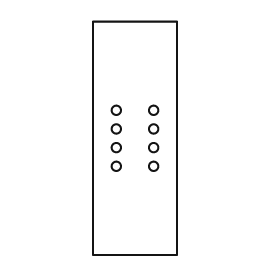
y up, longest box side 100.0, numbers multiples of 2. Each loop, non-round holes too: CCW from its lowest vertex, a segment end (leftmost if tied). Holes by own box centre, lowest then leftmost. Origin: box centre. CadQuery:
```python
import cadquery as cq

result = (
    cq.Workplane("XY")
    .moveTo(-18.0, -50.0)
    .lineTo(18.0, -50.0)
    .lineTo(18.0, 50.0)
    .lineTo(-18.0, 50.0)
    .close()
    .moveTo(-8.0, -12.0)
    .circle(2.0)
    .moveTo(8.0, -12.0)
    .circle(2.0)
    .moveTo(-8.0, -4.0)
    .circle(2.0)
    .moveTo(8.0, -4.0)
    .circle(2.0)
    .moveTo(-8.0, 4.0)
    .circle(2.0)
    .moveTo(8.0, 4.0)
    .circle(2.0)
    .moveTo(-8.0, 12.0)
    .circle(2.0)
    .moveTo(8.0, 12.0)
    .circle(2.0)
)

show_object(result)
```